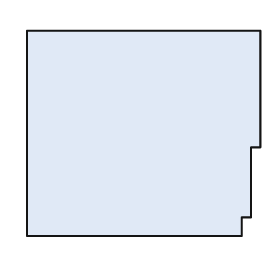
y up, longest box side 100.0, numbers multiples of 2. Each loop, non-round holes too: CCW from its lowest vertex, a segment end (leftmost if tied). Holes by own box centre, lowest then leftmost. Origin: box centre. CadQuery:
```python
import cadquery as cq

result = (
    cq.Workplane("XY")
    .moveTo(-50.0, -44.0)
    .lineTo(42.0, -44.0)
    .lineTo(42.0, -36.0)
    .lineTo(46.0, -36.0)
    .lineTo(46.0, -6.0)
    .lineTo(50.0, -6.0)
    .lineTo(50.0, 44.0)
    .lineTo(-50.0, 44.0)
    .close()
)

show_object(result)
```